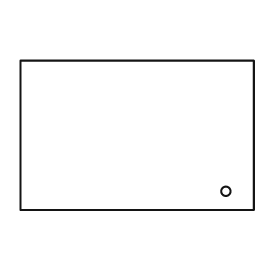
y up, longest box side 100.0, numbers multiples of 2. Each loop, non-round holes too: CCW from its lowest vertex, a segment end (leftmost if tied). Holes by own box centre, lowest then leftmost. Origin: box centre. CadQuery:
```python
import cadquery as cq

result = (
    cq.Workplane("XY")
    .moveTo(-50.0, -32.0)
    .lineTo(50.0, -32.0)
    .lineTo(50.0, 32.0)
    .lineTo(-50.0, 32.0)
    .close()
    .moveTo(38.0, -24.0)
    .circle(2.0)
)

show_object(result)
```